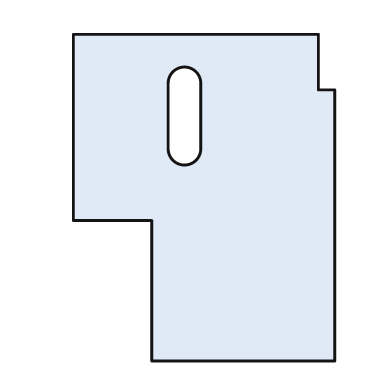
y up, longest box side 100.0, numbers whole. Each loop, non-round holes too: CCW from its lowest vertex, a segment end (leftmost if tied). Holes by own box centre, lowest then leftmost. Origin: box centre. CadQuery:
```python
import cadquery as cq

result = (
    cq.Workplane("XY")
    .moveTo(-16.0, -50.0)
    .lineTo(40.0, -50.0)
    .lineTo(40.0, 33.0)
    .lineTo(35.0, 33.0)
    .lineTo(35.0, 50.0)
    .lineTo(-40.0, 50.0)
    .lineTo(-40.0, -7.0)
    .lineTo(-16.0, -7.0)
    .close()
    .moveTo(-11.0, 15.0)
    .threePointArc((-6.0, 10.0), (-1.0, 15.0))
    .lineTo(-1.0, 35.0)
    .threePointArc((-6.0, 40.0), (-11.0, 35.0))
    .close()
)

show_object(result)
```